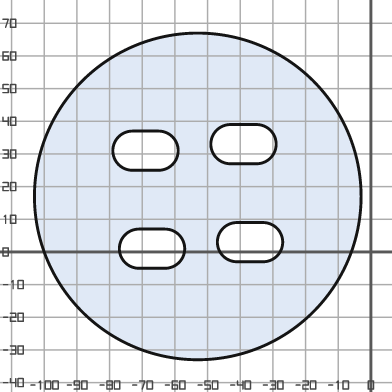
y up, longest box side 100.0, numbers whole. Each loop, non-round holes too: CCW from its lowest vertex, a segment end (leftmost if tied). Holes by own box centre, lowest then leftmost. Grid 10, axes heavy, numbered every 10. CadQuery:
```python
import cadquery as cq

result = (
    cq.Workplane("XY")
    .moveTo(-53.0, 17.0)
    .circle(50.0)
    .moveTo(-71.0, -5.0)
    .lineTo(-63.0, -5.0)
    .threePointArc((-57.0, 1.0), (-63.0, 7.0))
    .lineTo(-71.0, 7.0)
    .threePointArc((-77.0, 1.0), (-71.0, -5.0))
    .close()
    .moveTo(-41.0, -3.0)
    .lineTo(-33.0, -3.0)
    .threePointArc((-27.0, 3.0), (-33.0, 9.0))
    .lineTo(-41.0, 9.0)
    .threePointArc((-47.0, 3.0), (-41.0, -3.0))
    .close()
    .moveTo(-73.0, 25.0)
    .lineTo(-65.0, 25.0)
    .threePointArc((-59.0, 31.0), (-65.0, 37.0))
    .lineTo(-73.0, 37.0)
    .threePointArc((-79.0, 31.0), (-73.0, 25.0))
    .close()
    .moveTo(-43.0, 27.0)
    .lineTo(-35.0, 27.0)
    .threePointArc((-29.0, 33.0), (-35.0, 39.0))
    .lineTo(-43.0, 39.0)
    .threePointArc((-49.0, 33.0), (-43.0, 27.0))
    .close()
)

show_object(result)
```